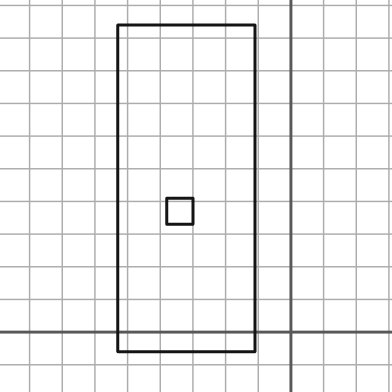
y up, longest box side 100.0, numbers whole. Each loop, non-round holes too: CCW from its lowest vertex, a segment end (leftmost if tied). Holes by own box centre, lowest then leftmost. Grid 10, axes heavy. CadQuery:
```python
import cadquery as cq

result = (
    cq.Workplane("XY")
    .moveTo(-53.0, -6.0)
    .lineTo(-11.0, -6.0)
    .lineTo(-11.0, 94.0)
    .lineTo(-53.0, 94.0)
    .close()
    .moveTo(-38.0, 33.0)
    .lineTo(-30.0, 33.0)
    .lineTo(-30.0, 41.0)
    .lineTo(-38.0, 41.0)
    .close()
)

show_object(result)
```